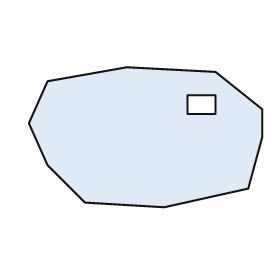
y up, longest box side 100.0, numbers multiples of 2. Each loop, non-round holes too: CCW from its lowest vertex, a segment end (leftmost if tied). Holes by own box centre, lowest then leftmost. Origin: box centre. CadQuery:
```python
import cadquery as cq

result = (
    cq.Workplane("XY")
    .moveTo(8.0, -30.0)
    .lineTo(44.0, -22.0)
    .lineTo(50.0, 0.0)
    .lineTo(50.0, 12.0)
    .lineTo(30.0, 28.0)
    .lineTo(-8.0, 30.0)
    .lineTo(-42.0, 24.0)
    .lineTo(-50.0, 6.0)
    .lineTo(-42.0, -12.0)
    .lineTo(-26.0, -28.0)
    .close()
    .moveTo(18.0, 10.0)
    .lineTo(30.0, 10.0)
    .lineTo(30.0, 18.0)
    .lineTo(18.0, 18.0)
    .close()
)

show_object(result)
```